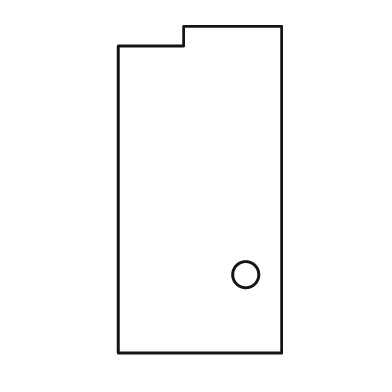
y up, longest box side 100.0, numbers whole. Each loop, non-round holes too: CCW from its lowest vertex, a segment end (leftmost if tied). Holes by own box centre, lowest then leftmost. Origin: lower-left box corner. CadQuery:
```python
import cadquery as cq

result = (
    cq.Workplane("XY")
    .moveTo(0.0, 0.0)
    .lineTo(50.0, 0.0)
    .lineTo(50.0, 100.0)
    .lineTo(20.0, 100.0)
    .lineTo(20.0, 94.0)
    .lineTo(0.0, 94.0)
    .close()
    .moveTo(39.0, 24.0)
    .circle(4.0)
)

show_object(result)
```